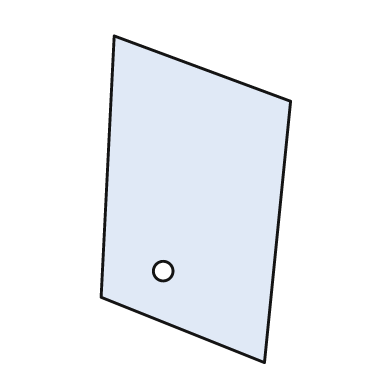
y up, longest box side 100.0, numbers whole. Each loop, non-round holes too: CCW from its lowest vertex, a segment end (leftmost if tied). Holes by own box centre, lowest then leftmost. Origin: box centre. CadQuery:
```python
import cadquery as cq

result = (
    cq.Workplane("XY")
    .moveTo(21.0, -50.0)
    .lineTo(29.0, 30.0)
    .lineTo(-25.0, 50.0)
    .lineTo(-29.0, -30.0)
    .close()
    .moveTo(-10.0, -22.0)
    .circle(3.0)
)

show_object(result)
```